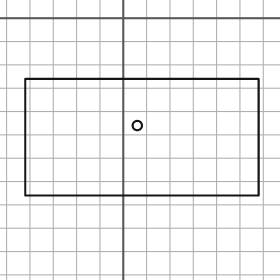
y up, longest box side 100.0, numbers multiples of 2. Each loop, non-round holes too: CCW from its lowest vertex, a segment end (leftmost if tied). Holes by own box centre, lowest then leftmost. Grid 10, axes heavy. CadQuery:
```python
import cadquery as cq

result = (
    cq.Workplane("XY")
    .moveTo(-42.0, -76.0)
    .lineTo(58.0, -76.0)
    .lineTo(58.0, -26.0)
    .lineTo(-42.0, -26.0)
    .close()
    .moveTo(6.0, -46.0)
    .circle(2.0)
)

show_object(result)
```